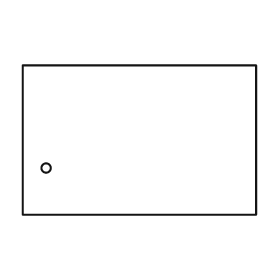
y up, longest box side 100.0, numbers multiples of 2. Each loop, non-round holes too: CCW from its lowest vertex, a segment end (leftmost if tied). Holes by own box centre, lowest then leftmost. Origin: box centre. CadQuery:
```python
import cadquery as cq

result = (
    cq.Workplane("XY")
    .moveTo(-50.0, -32.0)
    .lineTo(50.0, -32.0)
    .lineTo(50.0, 32.0)
    .lineTo(-50.0, 32.0)
    .close()
    .moveTo(-40.0, -12.0)
    .circle(2.0)
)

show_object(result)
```